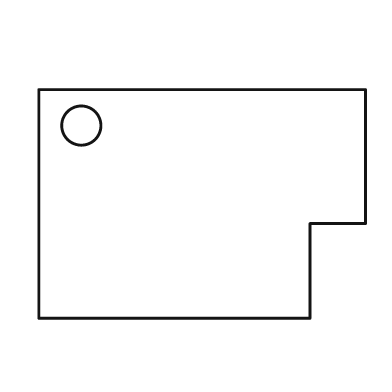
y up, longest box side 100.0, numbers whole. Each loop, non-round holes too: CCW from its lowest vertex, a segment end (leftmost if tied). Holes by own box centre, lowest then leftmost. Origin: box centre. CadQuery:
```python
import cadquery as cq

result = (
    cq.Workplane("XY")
    .moveTo(-50.0, -35.0)
    .lineTo(33.0, -35.0)
    .lineTo(33.0, -6.0)
    .lineTo(50.0, -6.0)
    .lineTo(50.0, 35.0)
    .lineTo(-50.0, 35.0)
    .close()
    .moveTo(-37.0, 24.0)
    .circle(6.0)
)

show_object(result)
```